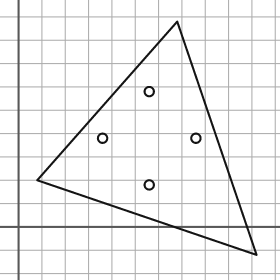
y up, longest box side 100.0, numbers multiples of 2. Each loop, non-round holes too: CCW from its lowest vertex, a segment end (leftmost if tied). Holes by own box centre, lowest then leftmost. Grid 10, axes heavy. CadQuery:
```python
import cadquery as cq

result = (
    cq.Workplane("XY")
    .moveTo(102.0, -12.0)
    .lineTo(68.0, 88.0)
    .lineTo(8.0, 20.0)
    .close()
    .moveTo(56.0, 18.0)
    .circle(2.0)
    .moveTo(36.0, 38.0)
    .circle(2.0)
    .moveTo(76.0, 38.0)
    .circle(2.0)
    .moveTo(56.0, 58.0)
    .circle(2.0)
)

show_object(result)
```